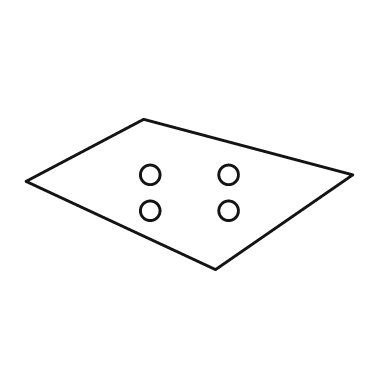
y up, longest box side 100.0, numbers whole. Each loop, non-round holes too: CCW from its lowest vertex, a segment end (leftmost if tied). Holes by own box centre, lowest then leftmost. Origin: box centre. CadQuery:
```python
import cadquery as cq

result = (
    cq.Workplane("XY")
    .moveTo(8.0, -23.0)
    .lineTo(50.0, 6.0)
    .lineTo(-14.0, 23.0)
    .lineTo(-50.0, 4.0)
    .close()
    .moveTo(-12.0, -5.0)
    .circle(3.0)
    .moveTo(12.0, -5.0)
    .circle(3.0)
    .moveTo(-12.0, 6.0)
    .circle(3.0)
    .moveTo(12.0, 6.0)
    .circle(3.0)
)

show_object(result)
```